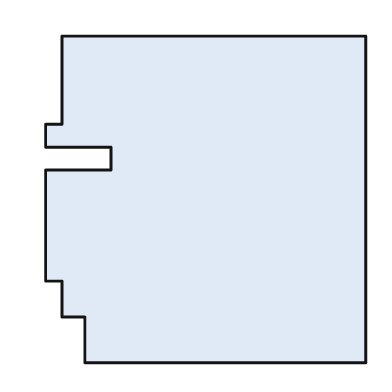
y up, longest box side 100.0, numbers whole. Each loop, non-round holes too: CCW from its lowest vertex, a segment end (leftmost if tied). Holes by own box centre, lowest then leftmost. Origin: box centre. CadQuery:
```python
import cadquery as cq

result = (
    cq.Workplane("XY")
    .moveTo(-37.0, -50.0)
    .lineTo(49.0, -50.0)
    .lineTo(49.0, 50.0)
    .lineTo(-44.0, 50.0)
    .lineTo(-44.0, 23.0)
    .lineTo(-49.0, 23.0)
    .lineTo(-49.0, 16.0)
    .lineTo(-29.0, 16.0)
    .lineTo(-29.0, 9.0)
    .lineTo(-49.0, 9.0)
    .lineTo(-49.0, -25.0)
    .lineTo(-44.0, -25.0)
    .lineTo(-44.0, -36.0)
    .lineTo(-37.0, -36.0)
    .close()
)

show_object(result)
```